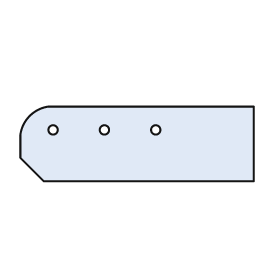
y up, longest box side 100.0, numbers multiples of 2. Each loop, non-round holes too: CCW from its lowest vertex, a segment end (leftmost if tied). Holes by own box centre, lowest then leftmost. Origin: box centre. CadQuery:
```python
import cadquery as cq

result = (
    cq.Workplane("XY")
    .moveTo(-40.0, -16.0)
    .lineTo(50.0, -16.0)
    .lineTo(50.0, 16.0)
    .lineTo(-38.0, 16.0)
    .threePointArc((-46.0, 12.0), (-50.0, 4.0))
    .lineTo(-50.0, -6.0)
    .close()
    .moveTo(-36.0, 6.0)
    .circle(2.0)
    .moveTo(-14.0, 6.0)
    .circle(2.0)
    .moveTo(8.0, 6.0)
    .circle(2.0)
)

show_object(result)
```